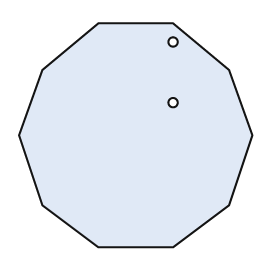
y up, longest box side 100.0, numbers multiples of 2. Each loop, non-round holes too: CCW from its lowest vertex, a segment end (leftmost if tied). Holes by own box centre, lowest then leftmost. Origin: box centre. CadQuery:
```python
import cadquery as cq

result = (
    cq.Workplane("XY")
    .moveTo(-16.0, -48.0)
    .lineTo(16.0, -48.0)
    .lineTo(40.0, -30.0)
    .lineTo(50.0, 0.0)
    .lineTo(40.0, 28.0)
    .lineTo(16.0, 48.0)
    .lineTo(-16.0, 48.0)
    .lineTo(-40.0, 28.0)
    .lineTo(-50.0, 0.0)
    .lineTo(-40.0, -30.0)
    .close()
    .moveTo(16.0, 14.0)
    .circle(2.0)
    .moveTo(16.0, 40.0)
    .circle(2.0)
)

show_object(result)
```